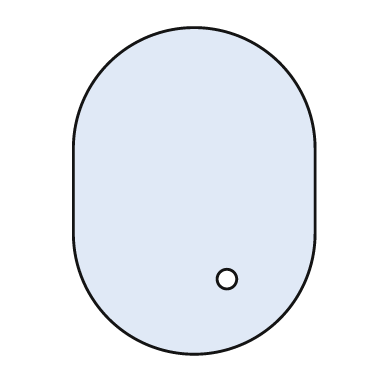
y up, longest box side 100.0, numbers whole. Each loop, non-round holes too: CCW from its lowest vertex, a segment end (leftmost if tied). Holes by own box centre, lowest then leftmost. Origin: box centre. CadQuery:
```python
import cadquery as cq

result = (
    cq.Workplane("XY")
    .moveTo(-37.0, -13.0)
    .threePointArc((0.0, -50.0), (37.0, -13.0))
    .lineTo(37.0, 13.0)
    .threePointArc((0.0, 50.0), (-37.0, 13.0))
    .close()
    .moveTo(10.0, -27.0)
    .circle(3.0)
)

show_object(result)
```